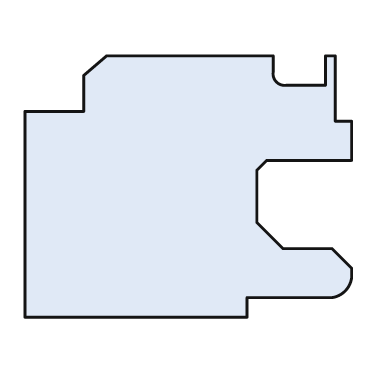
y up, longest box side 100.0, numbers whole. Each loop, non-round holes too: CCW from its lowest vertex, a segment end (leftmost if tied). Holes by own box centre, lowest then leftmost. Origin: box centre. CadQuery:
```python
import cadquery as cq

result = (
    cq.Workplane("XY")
    .moveTo(-50.0, -40.0)
    .lineTo(18.0, -40.0)
    .lineTo(18.0, -34.0)
    .lineTo(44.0, -34.0)
    .threePointArc((48.0, -32.0), (50.0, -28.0))
    .lineTo(50.0, -25.0)
    .lineTo(44.0, -19.0)
    .lineTo(29.0, -19.0)
    .lineTo(21.0, -11.0)
    .lineTo(21.0, 5.0)
    .lineTo(24.0, 8.0)
    .lineTo(50.0, 8.0)
    .lineTo(50.0, 20.0)
    .lineTo(45.0, 20.0)
    .lineTo(45.0, 40.0)
    .lineTo(42.0, 40.0)
    .lineTo(42.0, 31.0)
    .lineTo(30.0, 31.0)
    .threePointArc((27.0, 32.0), (26.0, 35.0))
    .lineTo(26.0, 40.0)
    .lineTo(-25.0, 40.0)
    .lineTo(-32.0, 34.0)
    .lineTo(-32.0, 23.0)
    .lineTo(-50.0, 23.0)
    .close()
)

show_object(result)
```